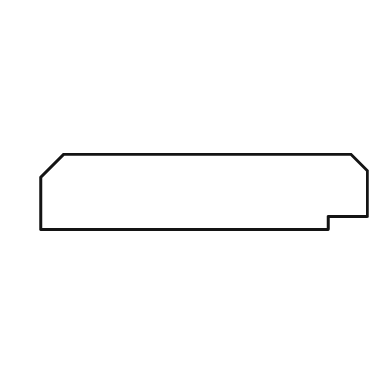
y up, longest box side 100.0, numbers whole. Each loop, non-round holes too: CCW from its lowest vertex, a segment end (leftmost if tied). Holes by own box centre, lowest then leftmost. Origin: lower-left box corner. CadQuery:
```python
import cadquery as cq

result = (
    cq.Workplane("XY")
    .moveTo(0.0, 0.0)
    .lineTo(88.0, 0.0)
    .lineTo(88.0, 4.0)
    .lineTo(100.0, 4.0)
    .lineTo(100.0, 18.0)
    .lineTo(95.0, 23.0)
    .lineTo(7.0, 23.0)
    .lineTo(0.0, 16.0)
    .close()
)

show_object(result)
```